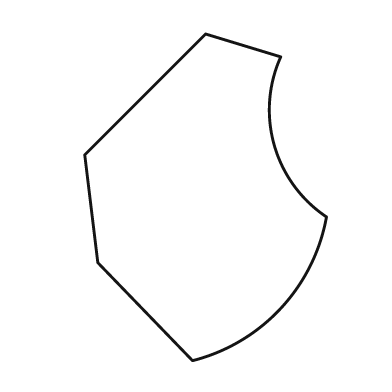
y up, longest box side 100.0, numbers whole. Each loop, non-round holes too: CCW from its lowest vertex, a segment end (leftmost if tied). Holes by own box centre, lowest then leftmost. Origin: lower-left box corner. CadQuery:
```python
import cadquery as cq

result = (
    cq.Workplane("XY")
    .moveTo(33.0, 0.0)
    .threePointArc((60.0, 16.0), (74.0, 44.0))
    .threePointArc((58.0, 66.0), (60.0, 93.0))
    .lineTo(37.0, 100.0)
    .lineTo(0.0, 63.0)
    .lineTo(4.0, 30.0)
    .close()
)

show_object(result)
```